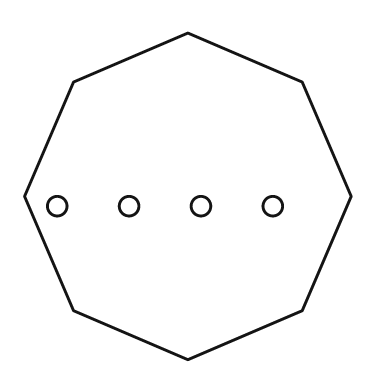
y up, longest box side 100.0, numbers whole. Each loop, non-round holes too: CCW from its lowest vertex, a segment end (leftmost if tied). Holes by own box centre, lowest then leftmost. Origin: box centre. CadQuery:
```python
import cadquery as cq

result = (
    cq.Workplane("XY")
    .moveTo(0.0, -50.0)
    .lineTo(35.0, -35.0)
    .lineTo(50.0, 0.0)
    .lineTo(35.0, 35.0)
    .lineTo(0.0, 50.0)
    .lineTo(-35.0, 35.0)
    .lineTo(-50.0, 0.0)
    .lineTo(-35.0, -35.0)
    .close()
    .moveTo(-40.0, -3.0)
    .circle(3.0)
    .moveTo(-18.0, -3.0)
    .circle(3.0)
    .moveTo(4.0, -3.0)
    .circle(3.0)
    .moveTo(26.0, -3.0)
    .circle(3.0)
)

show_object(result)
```